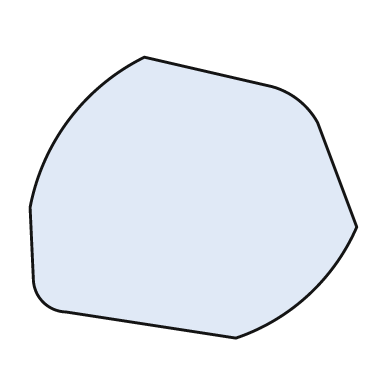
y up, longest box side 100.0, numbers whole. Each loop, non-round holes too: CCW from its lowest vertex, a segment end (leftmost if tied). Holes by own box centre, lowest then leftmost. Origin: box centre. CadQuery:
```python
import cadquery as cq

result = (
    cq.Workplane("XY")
    .moveTo(13.0, -43.0)
    .threePointArc((35.0, -30.0), (50.0, -9.0))
    .lineTo(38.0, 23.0)
    .threePointArc((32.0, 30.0), (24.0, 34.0))
    .lineTo(-15.0, 43.0)
    .threePointArc((-38.0, 24.0), (-50.0, -3.0))
    .lineTo(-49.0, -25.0)
    .threePointArc((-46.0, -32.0), (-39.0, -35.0))
    .close()
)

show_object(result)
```